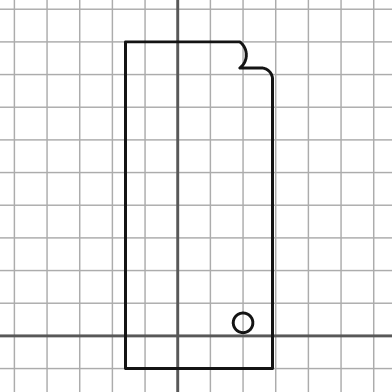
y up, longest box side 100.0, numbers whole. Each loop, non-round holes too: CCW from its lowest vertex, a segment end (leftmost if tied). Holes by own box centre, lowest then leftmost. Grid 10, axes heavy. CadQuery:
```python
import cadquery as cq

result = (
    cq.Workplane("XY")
    .moveTo(-16.0, -10.0)
    .lineTo(29.0, -10.0)
    .lineTo(29.0, 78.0)
    .threePointArc((28.0, 81.0), (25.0, 82.0))
    .lineTo(19.0, 82.0)
    .threePointArc((21.0, 86.0), (19.0, 90.0))
    .lineTo(-16.0, 90.0)
    .close()
    .moveTo(20.0, 4.0)
    .circle(3.0)
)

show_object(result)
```